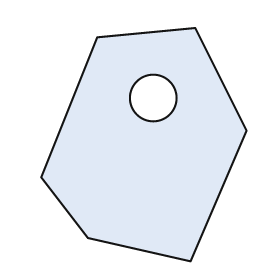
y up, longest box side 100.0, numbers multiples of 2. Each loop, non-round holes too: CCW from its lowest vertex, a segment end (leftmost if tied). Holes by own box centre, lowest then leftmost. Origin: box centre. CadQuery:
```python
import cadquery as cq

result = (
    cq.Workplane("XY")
    .moveTo(20.0, -50.0)
    .lineTo(44.0, 6.0)
    .lineTo(22.0, 50.0)
    .lineTo(-20.0, 46.0)
    .lineTo(-44.0, -14.0)
    .lineTo(-24.0, -40.0)
    .close()
    .moveTo(4.0, 20.0)
    .circle(10.0)
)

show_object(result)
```